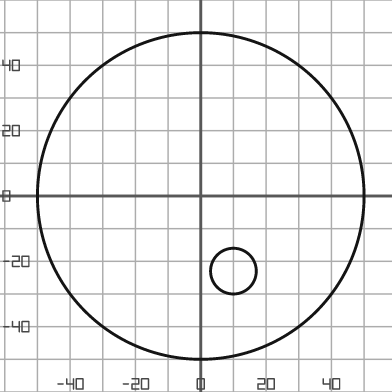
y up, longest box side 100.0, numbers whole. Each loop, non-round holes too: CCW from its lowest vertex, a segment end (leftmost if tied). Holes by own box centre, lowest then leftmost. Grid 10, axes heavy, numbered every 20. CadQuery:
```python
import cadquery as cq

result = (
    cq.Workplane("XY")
    .moveTo(0.0, 0.0)
    .circle(50.0)
    .moveTo(10.0, -23.0)
    .circle(7.0)
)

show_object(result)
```